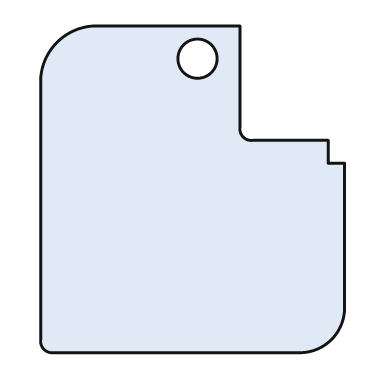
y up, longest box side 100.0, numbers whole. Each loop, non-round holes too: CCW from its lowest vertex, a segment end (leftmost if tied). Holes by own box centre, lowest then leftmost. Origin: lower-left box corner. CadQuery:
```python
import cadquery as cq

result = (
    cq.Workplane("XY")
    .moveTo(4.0, 0.0)
    .lineTo(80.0, 0.0)
    .threePointArc((89.0, 4.0), (93.0, 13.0))
    .lineTo(93.0, 58.0)
    .lineTo(88.0, 58.0)
    .lineTo(88.0, 65.0)
    .lineTo(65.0, 65.0)
    .threePointArc((62.0, 66.0), (61.0, 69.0))
    .lineTo(61.0, 100.0)
    .lineTo(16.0, 100.0)
    .threePointArc((5.0, 95.0), (0.0, 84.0))
    .lineTo(0.0, 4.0)
    .threePointArc((1.0, 1.0), (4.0, 0.0))
    .close()
    .moveTo(48.0, 90.0)
    .circle(6.0)
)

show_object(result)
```